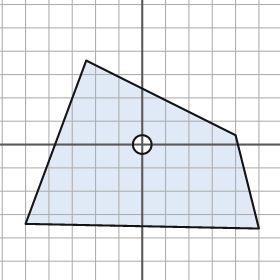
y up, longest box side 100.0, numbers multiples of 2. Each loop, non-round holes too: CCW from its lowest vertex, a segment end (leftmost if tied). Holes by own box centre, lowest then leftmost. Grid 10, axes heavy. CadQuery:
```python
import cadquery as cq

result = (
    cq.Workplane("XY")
    .moveTo(50.0, -36.0)
    .lineTo(40.0, 4.0)
    .lineTo(-24.0, 36.0)
    .lineTo(-50.0, -34.0)
    .close()
    .moveTo(0.0, 0.0)
    .circle(4.0)
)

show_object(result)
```